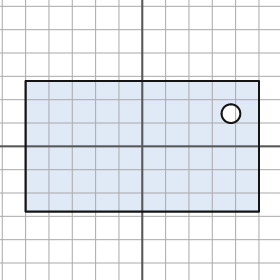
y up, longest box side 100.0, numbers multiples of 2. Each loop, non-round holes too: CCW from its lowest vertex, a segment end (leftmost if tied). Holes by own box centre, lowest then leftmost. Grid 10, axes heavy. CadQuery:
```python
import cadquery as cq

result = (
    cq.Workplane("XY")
    .moveTo(-50.0, -28.0)
    .lineTo(50.0, -28.0)
    .lineTo(50.0, 28.0)
    .lineTo(-50.0, 28.0)
    .close()
    .moveTo(38.0, 14.0)
    .circle(4.0)
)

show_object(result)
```